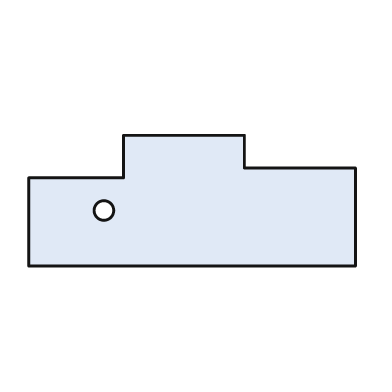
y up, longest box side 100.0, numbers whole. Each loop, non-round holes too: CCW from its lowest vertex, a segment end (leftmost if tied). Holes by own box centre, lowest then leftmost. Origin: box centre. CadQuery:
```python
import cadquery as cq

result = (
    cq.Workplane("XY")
    .moveTo(-50.0, -20.0)
    .lineTo(50.0, -20.0)
    .lineTo(50.0, 10.0)
    .lineTo(16.0, 10.0)
    .lineTo(16.0, 20.0)
    .lineTo(-21.0, 20.0)
    .lineTo(-21.0, 7.0)
    .lineTo(-50.0, 7.0)
    .close()
    .moveTo(-27.0, -3.0)
    .circle(3.0)
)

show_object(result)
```